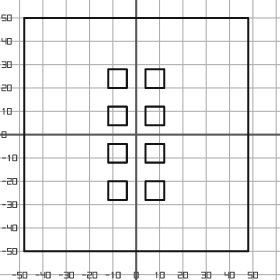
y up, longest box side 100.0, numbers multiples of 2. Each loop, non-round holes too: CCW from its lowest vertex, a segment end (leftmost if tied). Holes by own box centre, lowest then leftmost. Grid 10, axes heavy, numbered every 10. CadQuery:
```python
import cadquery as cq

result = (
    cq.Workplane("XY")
    .moveTo(-48.0, -50.0)
    .lineTo(48.0, -50.0)
    .lineTo(48.0, 50.0)
    .lineTo(-48.0, 50.0)
    .close()
    .moveTo(-12.0, -28.0)
    .lineTo(-4.0, -28.0)
    .lineTo(-4.0, -20.0)
    .lineTo(-12.0, -20.0)
    .close()
    .moveTo(4.0, -28.0)
    .lineTo(12.0, -28.0)
    .lineTo(12.0, -20.0)
    .lineTo(4.0, -20.0)
    .close()
    .moveTo(-12.0, -12.0)
    .lineTo(-4.0, -12.0)
    .lineTo(-4.0, -4.0)
    .lineTo(-12.0, -4.0)
    .close()
    .moveTo(4.0, -12.0)
    .lineTo(12.0, -12.0)
    .lineTo(12.0, -4.0)
    .lineTo(4.0, -4.0)
    .close()
    .moveTo(-12.0, 4.0)
    .lineTo(-4.0, 4.0)
    .lineTo(-4.0, 12.0)
    .lineTo(-12.0, 12.0)
    .close()
    .moveTo(4.0, 4.0)
    .lineTo(12.0, 4.0)
    .lineTo(12.0, 12.0)
    .lineTo(4.0, 12.0)
    .close()
    .moveTo(-12.0, 20.0)
    .lineTo(-4.0, 20.0)
    .lineTo(-4.0, 28.0)
    .lineTo(-12.0, 28.0)
    .close()
    .moveTo(4.0, 20.0)
    .lineTo(12.0, 20.0)
    .lineTo(12.0, 28.0)
    .lineTo(4.0, 28.0)
    .close()
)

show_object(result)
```